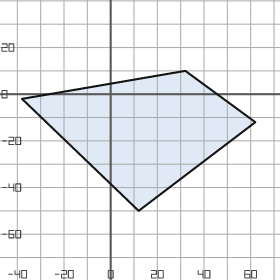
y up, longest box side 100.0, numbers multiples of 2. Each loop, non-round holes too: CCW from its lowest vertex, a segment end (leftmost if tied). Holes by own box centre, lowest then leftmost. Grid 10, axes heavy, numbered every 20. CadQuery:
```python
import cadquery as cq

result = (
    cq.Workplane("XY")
    .moveTo(12.0, -50.0)
    .lineTo(62.0, -12.0)
    .lineTo(32.0, 10.0)
    .lineTo(-38.0, -2.0)
    .close()
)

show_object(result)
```